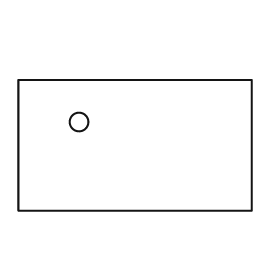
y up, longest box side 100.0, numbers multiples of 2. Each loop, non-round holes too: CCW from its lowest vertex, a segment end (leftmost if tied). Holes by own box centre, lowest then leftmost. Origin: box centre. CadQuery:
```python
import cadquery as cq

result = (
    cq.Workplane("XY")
    .moveTo(-50.0, -28.0)
    .lineTo(50.0, -28.0)
    .lineTo(50.0, 28.0)
    .lineTo(-50.0, 28.0)
    .close()
    .moveTo(-24.0, 10.0)
    .circle(4.0)
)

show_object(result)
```